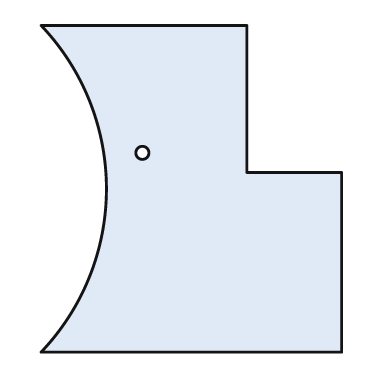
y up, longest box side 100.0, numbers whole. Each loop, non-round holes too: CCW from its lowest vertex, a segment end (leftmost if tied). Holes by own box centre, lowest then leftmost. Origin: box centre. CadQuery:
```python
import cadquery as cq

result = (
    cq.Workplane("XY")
    .moveTo(-46.0, -50.0)
    .lineTo(46.0, -50.0)
    .lineTo(46.0, 5.0)
    .lineTo(17.0, 5.0)
    .lineTo(17.0, 50.0)
    .lineTo(-46.0, 50.0)
    .threePointArc((-26.0, 0.0), (-46.0, -50.0))
    .close()
    .moveTo(-15.0, 11.0)
    .circle(2.0)
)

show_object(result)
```